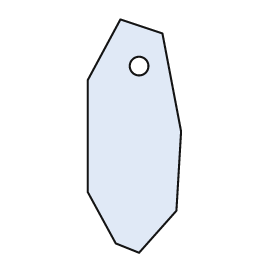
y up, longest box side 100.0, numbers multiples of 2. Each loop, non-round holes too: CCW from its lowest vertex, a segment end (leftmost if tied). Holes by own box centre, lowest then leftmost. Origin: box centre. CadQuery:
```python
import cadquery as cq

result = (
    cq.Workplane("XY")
    .moveTo(2.0, -50.0)
    .lineTo(18.0, -32.0)
    .lineTo(20.0, 2.0)
    .lineTo(12.0, 44.0)
    .lineTo(-6.0, 50.0)
    .lineTo(-20.0, 24.0)
    .lineTo(-20.0, -24.0)
    .lineTo(-8.0, -46.0)
    .close()
    .moveTo(2.0, 30.0)
    .circle(4.0)
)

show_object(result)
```